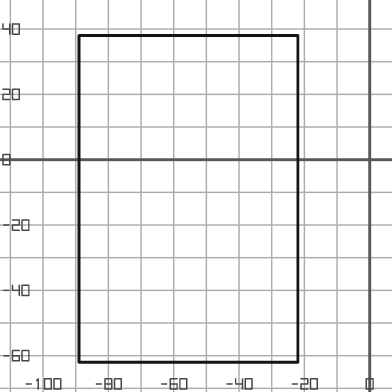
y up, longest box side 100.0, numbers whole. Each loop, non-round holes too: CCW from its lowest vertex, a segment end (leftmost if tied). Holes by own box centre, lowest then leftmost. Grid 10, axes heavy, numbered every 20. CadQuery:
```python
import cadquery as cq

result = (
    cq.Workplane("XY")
    .moveTo(-89.0, -62.0)
    .lineTo(-22.0, -62.0)
    .lineTo(-22.0, 38.0)
    .lineTo(-89.0, 38.0)
    .close()
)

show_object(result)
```